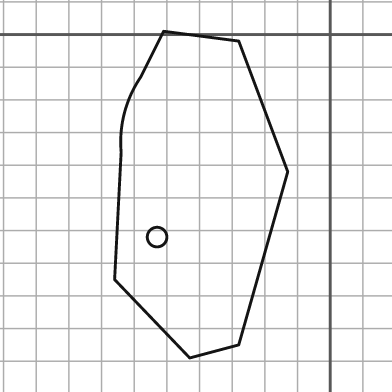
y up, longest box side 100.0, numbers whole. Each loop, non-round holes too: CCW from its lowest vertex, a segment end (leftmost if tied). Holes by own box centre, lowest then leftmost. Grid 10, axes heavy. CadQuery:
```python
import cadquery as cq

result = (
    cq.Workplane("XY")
    .moveTo(-43.0, -99.0)
    .lineTo(-28.0, -95.0)
    .lineTo(-13.0, -42.0)
    .lineTo(-28.0, -2.0)
    .lineTo(-51.0, 1.0)
    .lineTo(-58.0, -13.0)
    .threePointArc((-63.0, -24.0), (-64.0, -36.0))
    .lineTo(-66.0, -75.0)
    .close()
    .moveTo(-53.0, -62.0)
    .circle(3.0)
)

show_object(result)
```